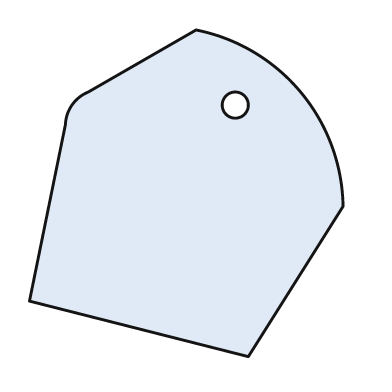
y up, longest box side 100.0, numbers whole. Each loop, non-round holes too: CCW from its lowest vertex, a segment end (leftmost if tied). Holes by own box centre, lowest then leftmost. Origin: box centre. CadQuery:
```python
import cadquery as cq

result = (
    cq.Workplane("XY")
    .moveTo(19.0, -50.0)
    .lineTo(48.0, -4.0)
    .threePointArc((35.0, 31.0), (3.0, 50.0))
    .lineTo(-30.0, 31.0)
    .threePointArc((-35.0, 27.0), (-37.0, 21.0))
    .lineTo(-48.0, -33.0)
    .close()
    .moveTo(15.0, 27.0)
    .circle(4.0)
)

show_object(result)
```